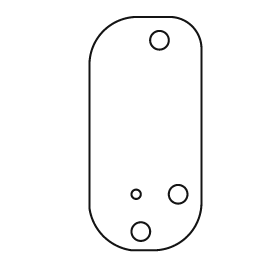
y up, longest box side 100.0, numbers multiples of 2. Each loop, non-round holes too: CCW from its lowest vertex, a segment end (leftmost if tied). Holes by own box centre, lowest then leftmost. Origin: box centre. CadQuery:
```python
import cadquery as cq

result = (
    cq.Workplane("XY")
    .moveTo(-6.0, -50.0)
    .lineTo(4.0, -50.0)
    .threePointArc((18.0, -44.0), (24.0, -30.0))
    .lineTo(24.0, 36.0)
    .threePointArc((20.0, 46.0), (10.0, 50.0))
    .lineTo(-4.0, 50.0)
    .threePointArc((-18.0, 44.0), (-24.0, 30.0))
    .lineTo(-24.0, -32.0)
    .threePointArc((-18.0, -44.0), (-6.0, -50.0))
    .close()
    .moveTo(-2.0, -42.0)
    .circle(4.0)
    .moveTo(-4.0, -26.0)
    .circle(2.0)
    .moveTo(14.0, -26.0)
    .circle(4.0)
    .moveTo(6.0, 40.0)
    .circle(4.0)
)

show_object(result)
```